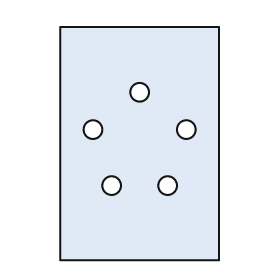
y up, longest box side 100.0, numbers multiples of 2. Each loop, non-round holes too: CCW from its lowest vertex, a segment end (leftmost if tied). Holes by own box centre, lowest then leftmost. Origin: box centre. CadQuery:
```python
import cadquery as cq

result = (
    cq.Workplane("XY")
    .moveTo(-34.0, -50.0)
    .lineTo(34.0, -50.0)
    .lineTo(34.0, 50.0)
    .lineTo(-34.0, 50.0)
    .close()
    .moveTo(-12.0, -18.0)
    .circle(4.0)
    .moveTo(12.0, -18.0)
    .circle(4.0)
    .moveTo(-20.0, 6.0)
    .circle(4.0)
    .moveTo(20.0, 6.0)
    .circle(4.0)
    .moveTo(0.0, 22.0)
    .circle(4.0)
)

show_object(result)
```